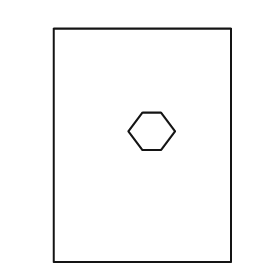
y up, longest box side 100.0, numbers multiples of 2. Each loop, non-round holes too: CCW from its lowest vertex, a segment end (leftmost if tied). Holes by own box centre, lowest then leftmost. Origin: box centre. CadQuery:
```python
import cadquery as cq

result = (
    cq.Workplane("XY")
    .moveTo(-38.0, -50.0)
    .lineTo(38.0, -50.0)
    .lineTo(38.0, 50.0)
    .lineTo(-38.0, 50.0)
    .close()
    .moveTo(0.0, -2.0)
    .lineTo(8.0, -2.0)
    .lineTo(14.0, 6.0)
    .lineTo(8.0, 14.0)
    .lineTo(0.0, 14.0)
    .lineTo(-6.0, 6.0)
    .close()
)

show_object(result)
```